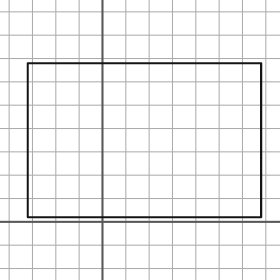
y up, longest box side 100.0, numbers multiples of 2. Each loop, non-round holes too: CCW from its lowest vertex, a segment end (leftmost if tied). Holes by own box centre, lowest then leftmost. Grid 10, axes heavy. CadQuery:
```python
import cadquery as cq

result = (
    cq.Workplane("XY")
    .moveTo(-32.0, 2.0)
    .lineTo(68.0, 2.0)
    .lineTo(68.0, 68.0)
    .lineTo(-32.0, 68.0)
    .close()
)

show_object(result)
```